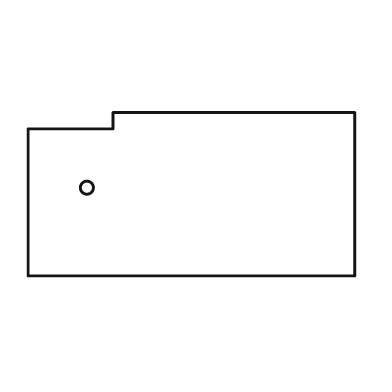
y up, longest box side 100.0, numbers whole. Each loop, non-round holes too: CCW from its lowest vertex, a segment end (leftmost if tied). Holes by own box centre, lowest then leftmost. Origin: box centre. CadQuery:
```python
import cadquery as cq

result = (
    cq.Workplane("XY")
    .moveTo(-50.0, -25.0)
    .lineTo(50.0, -25.0)
    .lineTo(50.0, 25.0)
    .lineTo(-24.0, 25.0)
    .lineTo(-24.0, 20.0)
    .lineTo(-50.0, 20.0)
    .close()
    .moveTo(-32.0, 2.0)
    .circle(2.0)
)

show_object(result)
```